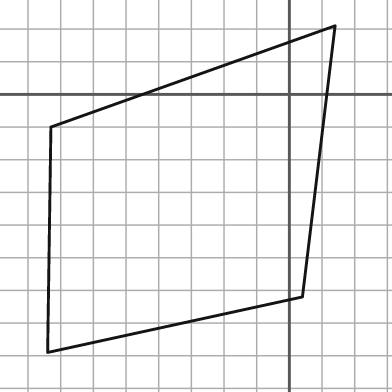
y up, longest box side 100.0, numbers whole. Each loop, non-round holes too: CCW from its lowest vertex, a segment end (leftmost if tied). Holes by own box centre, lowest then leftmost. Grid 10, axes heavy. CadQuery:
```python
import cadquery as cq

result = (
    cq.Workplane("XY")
    .moveTo(-74.0, -79.0)
    .lineTo(4.0, -62.0)
    .lineTo(14.0, 21.0)
    .lineTo(-73.0, -10.0)
    .close()
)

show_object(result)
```